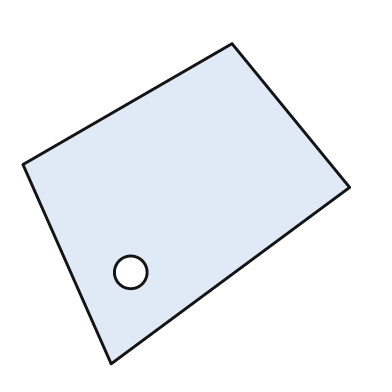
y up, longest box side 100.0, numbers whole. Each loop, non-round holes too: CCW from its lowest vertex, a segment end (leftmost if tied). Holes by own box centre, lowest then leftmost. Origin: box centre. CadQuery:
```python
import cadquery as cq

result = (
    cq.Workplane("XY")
    .moveTo(-23.0, -49.0)
    .lineTo(50.0, 5.0)
    .lineTo(14.0, 49.0)
    .lineTo(-50.0, 12.0)
    .close()
    .moveTo(-17.0, -21.0)
    .circle(5.0)
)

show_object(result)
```